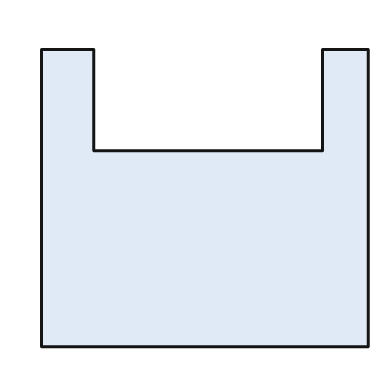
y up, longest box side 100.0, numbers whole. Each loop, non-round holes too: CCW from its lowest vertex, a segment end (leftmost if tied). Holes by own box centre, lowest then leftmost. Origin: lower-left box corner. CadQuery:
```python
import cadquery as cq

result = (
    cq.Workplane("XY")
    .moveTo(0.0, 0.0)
    .lineTo(100.0, 0.0)
    .lineTo(100.0, 91.0)
    .lineTo(86.0, 91.0)
    .lineTo(86.0, 60.0)
    .lineTo(16.0, 60.0)
    .lineTo(16.0, 91.0)
    .lineTo(0.0, 91.0)
    .close()
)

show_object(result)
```